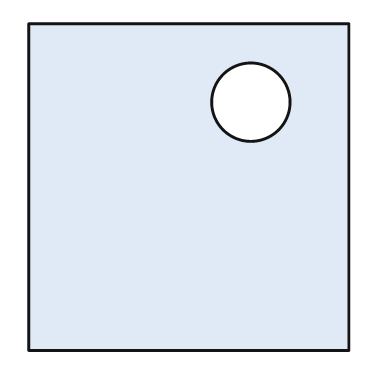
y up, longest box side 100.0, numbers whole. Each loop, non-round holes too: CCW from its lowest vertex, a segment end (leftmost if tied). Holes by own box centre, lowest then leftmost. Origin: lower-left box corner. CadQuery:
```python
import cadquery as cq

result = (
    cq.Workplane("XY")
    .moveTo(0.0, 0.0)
    .lineTo(98.0, 0.0)
    .lineTo(98.0, 100.0)
    .lineTo(0.0, 100.0)
    .close()
    .moveTo(68.0, 76.0)
    .circle(12.0)
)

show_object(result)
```